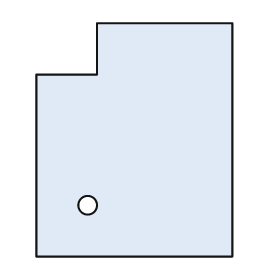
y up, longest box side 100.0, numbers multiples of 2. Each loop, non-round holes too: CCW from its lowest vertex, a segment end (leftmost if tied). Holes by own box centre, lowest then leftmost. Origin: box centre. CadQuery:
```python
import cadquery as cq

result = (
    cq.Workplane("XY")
    .moveTo(-42.0, -50.0)
    .lineTo(42.0, -50.0)
    .lineTo(42.0, 50.0)
    .lineTo(-16.0, 50.0)
    .lineTo(-16.0, 28.0)
    .lineTo(-42.0, 28.0)
    .close()
    .moveTo(-20.0, -28.0)
    .circle(4.0)
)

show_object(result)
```